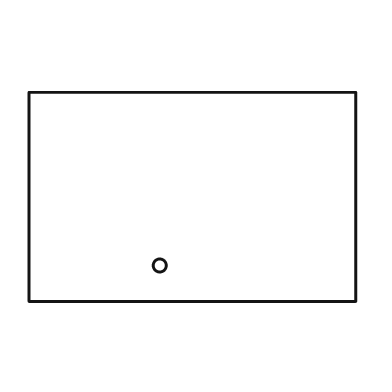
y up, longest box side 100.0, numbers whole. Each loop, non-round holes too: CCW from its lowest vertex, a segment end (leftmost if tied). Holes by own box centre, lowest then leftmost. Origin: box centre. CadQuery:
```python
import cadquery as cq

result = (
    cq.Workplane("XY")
    .moveTo(-50.0, -32.0)
    .lineTo(50.0, -32.0)
    .lineTo(50.0, 32.0)
    .lineTo(-50.0, 32.0)
    .close()
    .moveTo(-10.0, -21.0)
    .circle(2.0)
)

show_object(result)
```